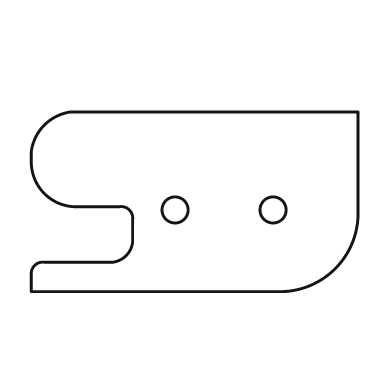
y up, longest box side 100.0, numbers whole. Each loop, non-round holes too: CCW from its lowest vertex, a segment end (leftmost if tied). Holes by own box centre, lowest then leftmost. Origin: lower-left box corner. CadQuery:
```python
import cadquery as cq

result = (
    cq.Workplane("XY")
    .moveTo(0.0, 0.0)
    .lineTo(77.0, 0.0)
    .threePointArc((93.0, 7.0), (100.0, 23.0))
    .lineTo(100.0, 55.0)
    .lineTo(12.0, 55.0)
    .threePointArc((4.0, 51.0), (0.0, 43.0))
    .lineTo(0.0, 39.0)
    .threePointArc((4.0, 30.0), (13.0, 26.0))
    .lineTo(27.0, 26.0)
    .threePointArc((30.0, 25.0), (31.0, 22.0))
    .lineTo(31.0, 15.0)
    .threePointArc((29.0, 11.0), (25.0, 9.0))
    .lineTo(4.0, 9.0)
    .threePointArc((1.0, 8.0), (0.0, 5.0))
    .close()
    .moveTo(44.0, 25.0)
    .circle(4.0)
    .moveTo(74.0, 25.0)
    .circle(4.0)
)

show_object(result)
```